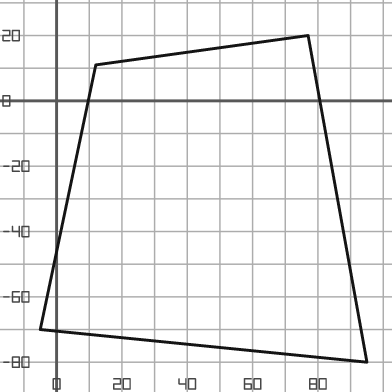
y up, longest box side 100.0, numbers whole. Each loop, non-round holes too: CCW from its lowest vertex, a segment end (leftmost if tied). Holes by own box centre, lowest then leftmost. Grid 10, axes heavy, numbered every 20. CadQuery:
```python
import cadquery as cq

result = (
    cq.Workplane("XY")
    .moveTo(95.0, -80.0)
    .lineTo(77.0, 20.0)
    .lineTo(12.0, 11.0)
    .lineTo(-5.0, -70.0)
    .close()
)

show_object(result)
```